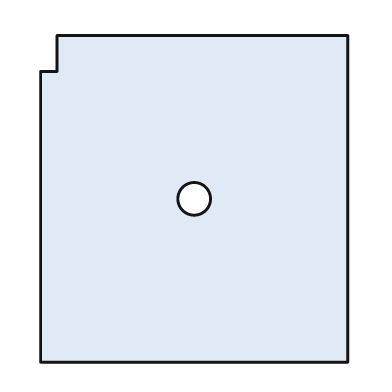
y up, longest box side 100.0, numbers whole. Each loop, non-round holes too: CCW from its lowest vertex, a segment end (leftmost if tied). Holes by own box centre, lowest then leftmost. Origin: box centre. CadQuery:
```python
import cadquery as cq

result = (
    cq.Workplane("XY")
    .moveTo(-47.0, -50.0)
    .lineTo(47.0, -50.0)
    .lineTo(47.0, 50.0)
    .lineTo(-42.0, 50.0)
    .lineTo(-42.0, 39.0)
    .lineTo(-47.0, 39.0)
    .close()
    .moveTo(0.0, 0.0)
    .circle(5.0)
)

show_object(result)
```